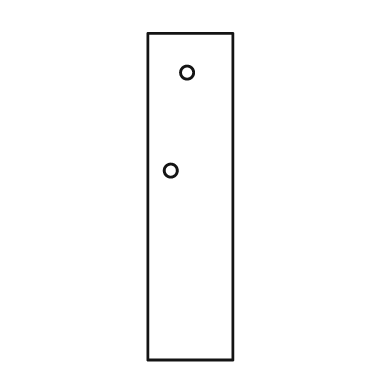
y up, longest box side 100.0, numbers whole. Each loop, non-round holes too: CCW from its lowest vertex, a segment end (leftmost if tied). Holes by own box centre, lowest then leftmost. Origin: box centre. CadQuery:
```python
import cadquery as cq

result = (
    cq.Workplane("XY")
    .moveTo(-13.0, -50.0)
    .lineTo(13.0, -50.0)
    .lineTo(13.0, 50.0)
    .lineTo(-13.0, 50.0)
    .close()
    .moveTo(-6.0, 8.0)
    .circle(2.0)
    .moveTo(-1.0, 38.0)
    .circle(2.0)
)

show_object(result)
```